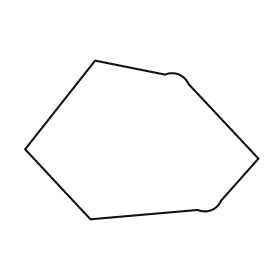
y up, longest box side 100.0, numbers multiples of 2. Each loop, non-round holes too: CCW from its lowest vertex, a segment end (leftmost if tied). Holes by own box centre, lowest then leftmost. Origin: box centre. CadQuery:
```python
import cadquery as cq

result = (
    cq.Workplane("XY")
    .moveTo(-22.0, -34.0)
    .lineTo(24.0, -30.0)
    .threePointArc((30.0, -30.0), (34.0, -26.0))
    .lineTo(50.0, -8.0)
    .lineTo(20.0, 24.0)
    .threePointArc((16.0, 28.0), (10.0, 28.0))
    .lineTo(-20.0, 34.0)
    .lineTo(-50.0, -4.0)
    .close()
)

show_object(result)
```